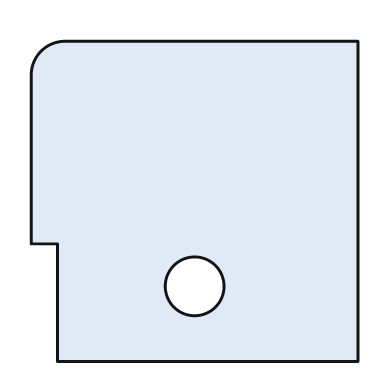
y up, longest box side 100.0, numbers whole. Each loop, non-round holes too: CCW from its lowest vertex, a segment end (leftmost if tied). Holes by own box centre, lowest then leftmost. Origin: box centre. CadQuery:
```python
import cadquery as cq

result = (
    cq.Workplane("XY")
    .moveTo(-42.0, -49.0)
    .lineTo(50.0, -49.0)
    .lineTo(50.0, 49.0)
    .lineTo(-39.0, 49.0)
    .threePointArc((-47.0, 46.0), (-50.0, 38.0))
    .lineTo(-50.0, -13.0)
    .lineTo(-42.0, -13.0)
    .close()
    .moveTo(0.0, -26.0)
    .circle(9.0)
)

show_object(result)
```